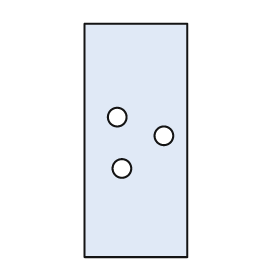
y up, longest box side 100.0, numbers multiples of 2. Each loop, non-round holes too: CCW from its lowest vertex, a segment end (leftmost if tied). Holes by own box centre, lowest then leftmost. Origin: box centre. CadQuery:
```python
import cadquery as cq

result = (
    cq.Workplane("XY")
    .moveTo(-22.0, -50.0)
    .lineTo(22.0, -50.0)
    .lineTo(22.0, 50.0)
    .lineTo(-22.0, 50.0)
    .close()
    .moveTo(-6.0, -12.0)
    .circle(4.0)
    .moveTo(12.0, 2.0)
    .circle(4.0)
    .moveTo(-8.0, 10.0)
    .circle(4.0)
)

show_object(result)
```